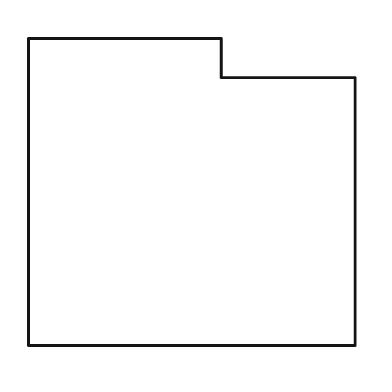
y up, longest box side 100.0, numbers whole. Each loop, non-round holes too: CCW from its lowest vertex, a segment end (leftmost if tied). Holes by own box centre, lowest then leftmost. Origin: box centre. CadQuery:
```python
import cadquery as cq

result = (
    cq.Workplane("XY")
    .moveTo(-50.0, -47.0)
    .lineTo(50.0, -47.0)
    .lineTo(50.0, 35.0)
    .lineTo(9.0, 35.0)
    .lineTo(9.0, 47.0)
    .lineTo(-50.0, 47.0)
    .close()
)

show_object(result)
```